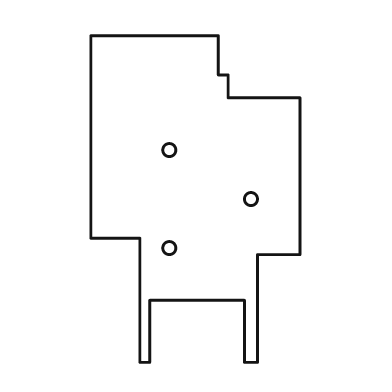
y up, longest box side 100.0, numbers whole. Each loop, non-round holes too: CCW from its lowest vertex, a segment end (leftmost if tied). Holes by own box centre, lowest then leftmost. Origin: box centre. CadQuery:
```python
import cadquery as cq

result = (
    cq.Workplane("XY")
    .moveTo(-17.0, -50.0)
    .lineTo(-14.0, -50.0)
    .lineTo(-14.0, -31.0)
    .lineTo(15.0, -31.0)
    .lineTo(15.0, -50.0)
    .lineTo(19.0, -50.0)
    .lineTo(19.0, -17.0)
    .lineTo(32.0, -17.0)
    .lineTo(32.0, 31.0)
    .lineTo(10.0, 31.0)
    .lineTo(10.0, 38.0)
    .lineTo(7.0, 38.0)
    .lineTo(7.0, 50.0)
    .lineTo(-32.0, 50.0)
    .lineTo(-32.0, -12.0)
    .lineTo(-17.0, -12.0)
    .close()
    .moveTo(-8.0, -15.0)
    .circle(2.0)
    .moveTo(17.0, 0.0)
    .circle(2.0)
    .moveTo(-8.0, 15.0)
    .circle(2.0)
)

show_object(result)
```